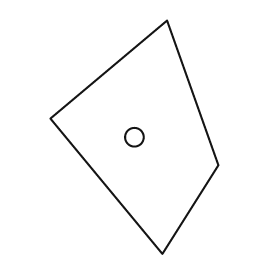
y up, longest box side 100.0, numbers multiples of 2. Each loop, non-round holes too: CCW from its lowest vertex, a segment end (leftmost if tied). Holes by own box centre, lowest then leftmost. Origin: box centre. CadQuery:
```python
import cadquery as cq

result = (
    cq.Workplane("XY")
    .moveTo(12.0, -50.0)
    .lineTo(36.0, -12.0)
    .lineTo(14.0, 50.0)
    .lineTo(-36.0, 8.0)
    .close()
    .moveTo(0.0, 0.0)
    .circle(4.0)
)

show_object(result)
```